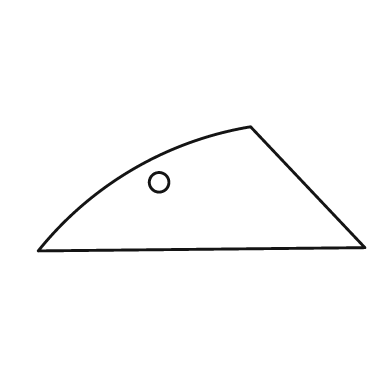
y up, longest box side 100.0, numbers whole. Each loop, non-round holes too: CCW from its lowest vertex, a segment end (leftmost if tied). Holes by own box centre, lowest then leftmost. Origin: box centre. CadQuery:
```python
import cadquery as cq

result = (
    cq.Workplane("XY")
    .moveTo(-50.0, -19.0)
    .lineTo(50.0, -18.0)
    .lineTo(15.0, 19.0)
    .threePointArc((-21.0, 6.0), (-50.0, -19.0))
    .close()
    .moveTo(-13.0, 2.0)
    .circle(3.0)
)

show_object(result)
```